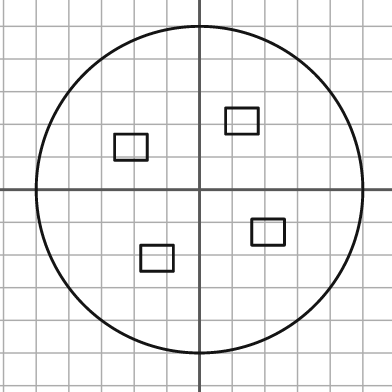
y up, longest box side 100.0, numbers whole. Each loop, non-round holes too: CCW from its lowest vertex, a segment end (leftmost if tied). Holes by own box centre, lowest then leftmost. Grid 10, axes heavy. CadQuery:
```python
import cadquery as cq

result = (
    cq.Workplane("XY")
    .moveTo(0.0, 0.0)
    .circle(50.0)
    .moveTo(-18.0, -25.0)
    .lineTo(-8.0, -25.0)
    .lineTo(-8.0, -17.0)
    .lineTo(-18.0, -17.0)
    .close()
    .moveTo(16.0, -17.0)
    .lineTo(26.0, -17.0)
    .lineTo(26.0, -9.0)
    .lineTo(16.0, -9.0)
    .close()
    .moveTo(-26.0, 9.0)
    .lineTo(-16.0, 9.0)
    .lineTo(-16.0, 17.0)
    .lineTo(-26.0, 17.0)
    .close()
    .moveTo(8.0, 17.0)
    .lineTo(18.0, 17.0)
    .lineTo(18.0, 25.0)
    .lineTo(8.0, 25.0)
    .close()
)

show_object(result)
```